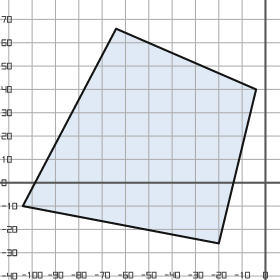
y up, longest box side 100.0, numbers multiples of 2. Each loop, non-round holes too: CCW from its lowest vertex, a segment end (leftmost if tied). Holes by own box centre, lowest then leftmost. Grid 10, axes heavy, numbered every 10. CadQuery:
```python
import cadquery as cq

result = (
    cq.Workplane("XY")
    .moveTo(-20.0, -26.0)
    .lineTo(-4.0, 40.0)
    .lineTo(-64.0, 66.0)
    .lineTo(-104.0, -10.0)
    .close()
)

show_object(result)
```